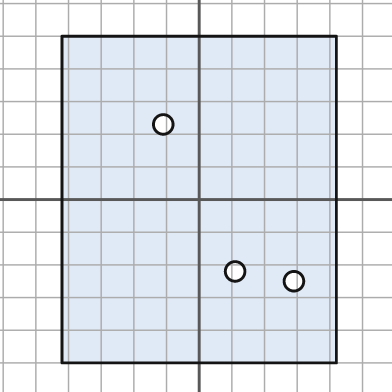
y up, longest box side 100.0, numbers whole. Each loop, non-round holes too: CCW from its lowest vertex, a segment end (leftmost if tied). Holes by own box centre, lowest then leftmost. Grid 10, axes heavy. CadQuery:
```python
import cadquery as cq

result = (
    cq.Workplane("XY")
    .moveTo(-42.0, -50.0)
    .lineTo(42.0, -50.0)
    .lineTo(42.0, 50.0)
    .lineTo(-42.0, 50.0)
    .close()
    .moveTo(29.0, -25.0)
    .circle(3.0)
    .moveTo(11.0, -22.0)
    .circle(3.0)
    .moveTo(-11.0, 23.0)
    .circle(3.0)
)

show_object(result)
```